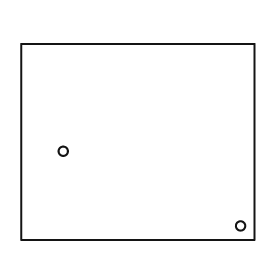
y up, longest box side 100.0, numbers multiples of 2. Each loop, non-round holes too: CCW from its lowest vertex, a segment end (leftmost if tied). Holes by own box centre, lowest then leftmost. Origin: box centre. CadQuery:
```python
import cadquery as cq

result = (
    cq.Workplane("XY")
    .moveTo(-50.0, -42.0)
    .lineTo(50.0, -42.0)
    .lineTo(50.0, 42.0)
    .lineTo(-50.0, 42.0)
    .close()
    .moveTo(44.0, -36.0)
    .circle(2.0)
    .moveTo(-32.0, -4.0)
    .circle(2.0)
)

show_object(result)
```